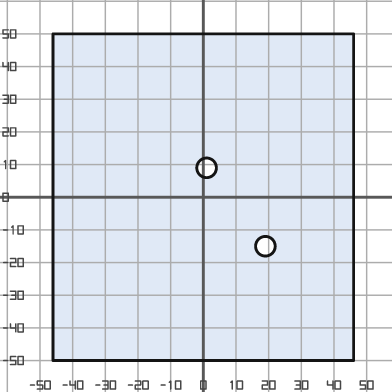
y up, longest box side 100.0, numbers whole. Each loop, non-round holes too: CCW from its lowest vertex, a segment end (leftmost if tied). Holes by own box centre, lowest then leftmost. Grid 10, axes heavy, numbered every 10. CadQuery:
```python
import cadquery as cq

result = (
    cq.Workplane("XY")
    .moveTo(-46.0, -50.0)
    .lineTo(46.0, -50.0)
    .lineTo(46.0, 50.0)
    .lineTo(-46.0, 50.0)
    .close()
    .moveTo(19.0, -15.0)
    .circle(3.0)
    .moveTo(1.0, 9.0)
    .circle(3.0)
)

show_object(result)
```